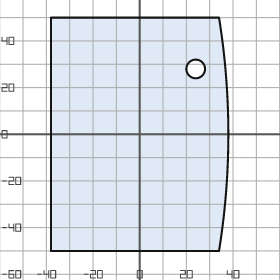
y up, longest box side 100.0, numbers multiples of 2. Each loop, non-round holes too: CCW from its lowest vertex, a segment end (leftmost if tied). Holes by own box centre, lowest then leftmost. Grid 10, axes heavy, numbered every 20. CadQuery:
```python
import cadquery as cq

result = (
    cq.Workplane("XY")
    .moveTo(-38.0, -50.0)
    .lineTo(34.0, -50.0)
    .threePointArc((38.0, 0.0), (34.0, 50.0))
    .lineTo(-38.0, 50.0)
    .close()
    .moveTo(24.0, 28.0)
    .circle(4.0)
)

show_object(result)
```